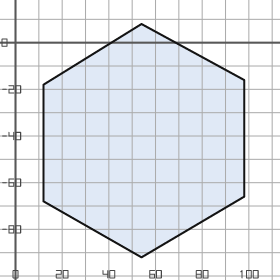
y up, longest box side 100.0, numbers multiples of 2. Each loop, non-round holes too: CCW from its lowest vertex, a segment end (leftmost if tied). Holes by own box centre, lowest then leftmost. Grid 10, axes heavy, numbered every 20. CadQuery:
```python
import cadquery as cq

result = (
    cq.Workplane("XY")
    .moveTo(54.0, -92.0)
    .lineTo(98.0, -66.0)
    .lineTo(98.0, -16.0)
    .lineTo(54.0, 8.0)
    .lineTo(12.0, -18.0)
    .lineTo(12.0, -68.0)
    .close()
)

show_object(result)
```